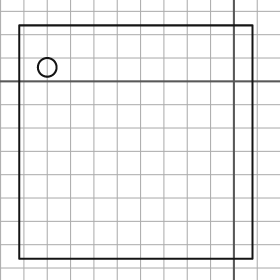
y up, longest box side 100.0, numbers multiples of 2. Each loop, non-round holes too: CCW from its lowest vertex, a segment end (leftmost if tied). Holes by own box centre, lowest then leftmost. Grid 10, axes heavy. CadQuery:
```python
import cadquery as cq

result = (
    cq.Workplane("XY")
    .moveTo(-92.0, -76.0)
    .lineTo(8.0, -76.0)
    .lineTo(8.0, 24.0)
    .lineTo(-92.0, 24.0)
    .close()
    .moveTo(-80.0, 6.0)
    .circle(4.0)
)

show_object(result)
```